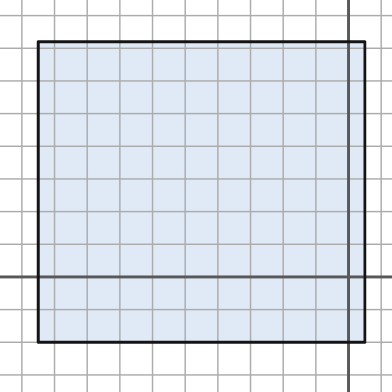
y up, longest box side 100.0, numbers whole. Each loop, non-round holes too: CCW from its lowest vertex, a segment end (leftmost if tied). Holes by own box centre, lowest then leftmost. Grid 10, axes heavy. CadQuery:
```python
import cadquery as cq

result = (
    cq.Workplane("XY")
    .moveTo(-95.0, -20.0)
    .lineTo(5.0, -20.0)
    .lineTo(5.0, 72.0)
    .lineTo(-95.0, 72.0)
    .close()
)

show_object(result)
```